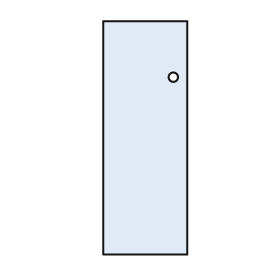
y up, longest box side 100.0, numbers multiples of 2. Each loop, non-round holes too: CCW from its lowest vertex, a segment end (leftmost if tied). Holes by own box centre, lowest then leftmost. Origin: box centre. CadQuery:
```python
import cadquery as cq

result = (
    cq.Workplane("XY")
    .moveTo(-18.0, -50.0)
    .lineTo(18.0, -50.0)
    .lineTo(18.0, 50.0)
    .lineTo(-18.0, 50.0)
    .close()
    .moveTo(12.0, 26.0)
    .circle(2.0)
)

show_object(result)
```